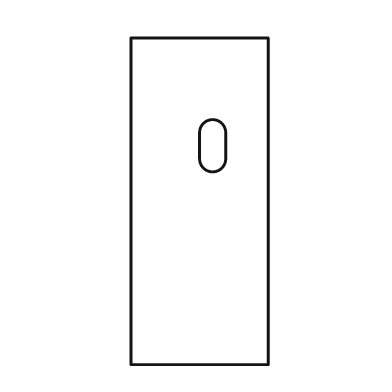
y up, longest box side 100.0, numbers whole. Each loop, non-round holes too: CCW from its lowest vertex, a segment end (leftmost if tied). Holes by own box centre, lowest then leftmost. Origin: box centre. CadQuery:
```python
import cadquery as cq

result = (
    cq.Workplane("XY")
    .moveTo(-21.0, -50.0)
    .lineTo(21.0, -50.0)
    .lineTo(21.0, 50.0)
    .lineTo(-21.0, 50.0)
    .close()
    .moveTo(0.0, 13.0)
    .threePointArc((4.0, 9.0), (8.0, 13.0))
    .lineTo(8.0, 21.0)
    .threePointArc((4.0, 25.0), (0.0, 21.0))
    .close()
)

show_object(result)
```